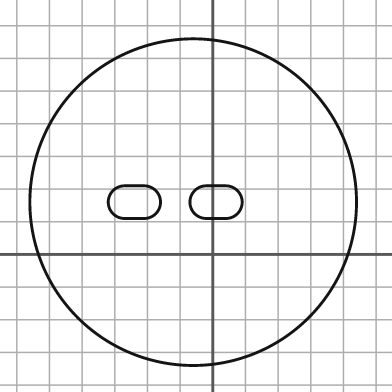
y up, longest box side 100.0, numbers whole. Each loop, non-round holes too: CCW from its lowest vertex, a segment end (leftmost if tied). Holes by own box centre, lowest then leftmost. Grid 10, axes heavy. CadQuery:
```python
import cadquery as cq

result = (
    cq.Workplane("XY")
    .moveTo(-6.0, 16.0)
    .circle(50.0)
    .moveTo(-27.0, 11.0)
    .lineTo(-21.0, 11.0)
    .threePointArc((-16.0, 16.0), (-21.0, 21.0))
    .lineTo(-27.0, 21.0)
    .threePointArc((-32.0, 16.0), (-27.0, 11.0))
    .close()
    .moveTo(-2.0, 11.0)
    .lineTo(4.0, 11.0)
    .threePointArc((9.0, 16.0), (4.0, 21.0))
    .lineTo(-2.0, 21.0)
    .threePointArc((-7.0, 16.0), (-2.0, 11.0))
    .close()
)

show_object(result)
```